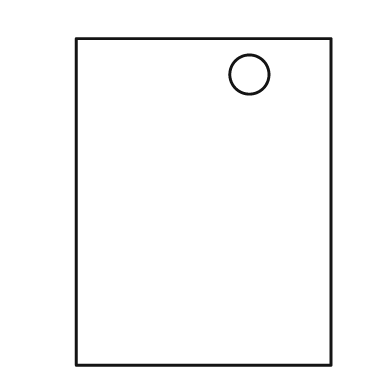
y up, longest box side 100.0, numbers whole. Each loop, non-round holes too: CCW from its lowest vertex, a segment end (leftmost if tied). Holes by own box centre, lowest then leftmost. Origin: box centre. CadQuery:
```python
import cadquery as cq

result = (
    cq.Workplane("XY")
    .moveTo(-39.0, -50.0)
    .lineTo(39.0, -50.0)
    .lineTo(39.0, 50.0)
    .lineTo(-39.0, 50.0)
    .close()
    .moveTo(14.0, 39.0)
    .circle(6.0)
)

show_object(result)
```